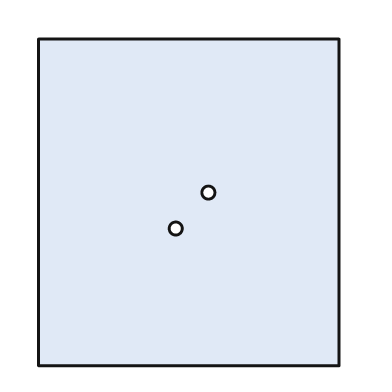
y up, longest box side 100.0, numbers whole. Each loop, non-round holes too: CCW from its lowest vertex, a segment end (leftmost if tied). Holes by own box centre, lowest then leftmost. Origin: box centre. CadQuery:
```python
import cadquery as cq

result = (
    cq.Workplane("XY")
    .moveTo(-46.0, -50.0)
    .lineTo(46.0, -50.0)
    .lineTo(46.0, 50.0)
    .lineTo(-46.0, 50.0)
    .close()
    .moveTo(-4.0, -8.0)
    .circle(2.0)
    .moveTo(6.0, 3.0)
    .circle(2.0)
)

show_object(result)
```